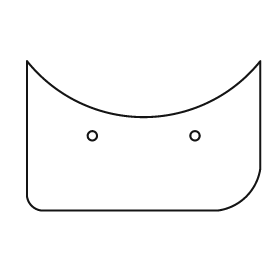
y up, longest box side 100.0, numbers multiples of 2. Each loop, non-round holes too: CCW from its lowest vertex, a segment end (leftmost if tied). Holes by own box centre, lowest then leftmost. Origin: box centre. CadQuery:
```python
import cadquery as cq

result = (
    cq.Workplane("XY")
    .moveTo(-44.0, -32.0)
    .lineTo(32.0, -32.0)
    .threePointArc((44.0, -26.0), (50.0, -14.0))
    .lineTo(50.0, 32.0)
    .threePointArc((0.0, 8.0), (-50.0, 32.0))
    .lineTo(-50.0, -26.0)
    .threePointArc((-48.0, -30.0), (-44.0, -32.0))
    .close()
    .moveTo(-22.0, 0.0)
    .circle(2.0)
    .moveTo(22.0, 0.0)
    .circle(2.0)
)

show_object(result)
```